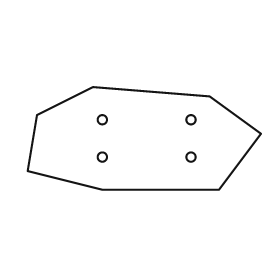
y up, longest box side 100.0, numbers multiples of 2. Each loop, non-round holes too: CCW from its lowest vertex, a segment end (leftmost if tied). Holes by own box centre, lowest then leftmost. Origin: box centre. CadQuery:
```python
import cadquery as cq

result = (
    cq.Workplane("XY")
    .moveTo(-18.0, -22.0)
    .lineTo(32.0, -22.0)
    .lineTo(50.0, 2.0)
    .lineTo(28.0, 18.0)
    .lineTo(-22.0, 22.0)
    .lineTo(-46.0, 10.0)
    .lineTo(-50.0, -14.0)
    .close()
    .moveTo(-18.0, -8.0)
    .circle(2.0)
    .moveTo(20.0, -8.0)
    .circle(2.0)
    .moveTo(-18.0, 8.0)
    .circle(2.0)
    .moveTo(20.0, 8.0)
    .circle(2.0)
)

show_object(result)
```